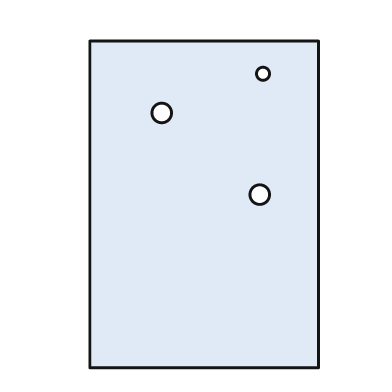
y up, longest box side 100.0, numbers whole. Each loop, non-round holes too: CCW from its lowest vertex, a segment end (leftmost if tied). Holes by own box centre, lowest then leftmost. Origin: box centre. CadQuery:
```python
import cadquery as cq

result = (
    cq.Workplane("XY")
    .moveTo(-35.0, -50.0)
    .lineTo(35.0, -50.0)
    .lineTo(35.0, 50.0)
    .lineTo(-35.0, 50.0)
    .close()
    .moveTo(17.0, 3.0)
    .circle(3.0)
    .moveTo(-13.0, 28.0)
    .circle(3.0)
    .moveTo(18.0, 40.0)
    .circle(2.0)
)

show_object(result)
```